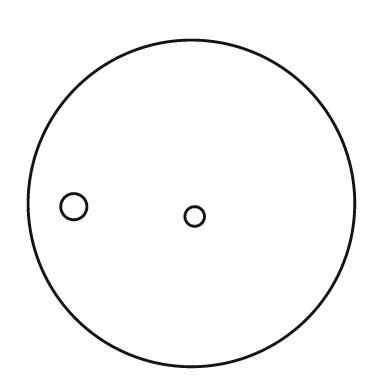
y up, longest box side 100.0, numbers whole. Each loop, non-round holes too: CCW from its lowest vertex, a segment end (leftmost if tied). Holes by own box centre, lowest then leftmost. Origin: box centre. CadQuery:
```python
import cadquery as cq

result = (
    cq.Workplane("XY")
    .moveTo(0.0, 0.0)
    .circle(50.0)
    .moveTo(1.0, -4.0)
    .circle(3.0)
    .moveTo(-36.0, -1.0)
    .circle(4.0)
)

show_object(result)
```